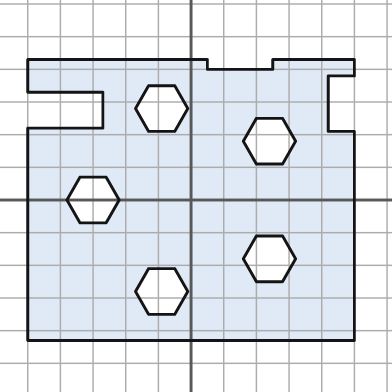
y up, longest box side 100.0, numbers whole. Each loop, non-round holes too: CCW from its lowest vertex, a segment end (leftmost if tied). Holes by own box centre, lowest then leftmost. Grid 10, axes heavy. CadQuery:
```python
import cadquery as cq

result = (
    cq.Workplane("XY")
    .moveTo(-50.0, -43.0)
    .lineTo(50.0, -43.0)
    .lineTo(50.0, 21.0)
    .lineTo(42.0, 21.0)
    .lineTo(42.0, 38.0)
    .lineTo(50.0, 38.0)
    .lineTo(50.0, 43.0)
    .lineTo(25.0, 43.0)
    .lineTo(25.0, 40.0)
    .lineTo(5.0, 40.0)
    .lineTo(5.0, 43.0)
    .lineTo(-50.0, 43.0)
    .lineTo(-50.0, 33.0)
    .lineTo(-27.0, 33.0)
    .lineTo(-27.0, 22.0)
    .lineTo(-50.0, 22.0)
    .close()
    .moveTo(-13.0, -35.0)
    .lineTo(-5.0, -35.0)
    .lineTo(-1.0, -28.0)
    .lineTo(-5.0, -21.0)
    .lineTo(-13.0, -21.0)
    .lineTo(-17.0, -28.0)
    .close()
    .moveTo(20.0, -25.0)
    .lineTo(28.0, -25.0)
    .lineTo(32.0, -18.0)
    .lineTo(28.0, -11.0)
    .lineTo(20.0, -11.0)
    .lineTo(16.0, -18.0)
    .close()
    .moveTo(-34.0, -7.0)
    .lineTo(-26.0, -7.0)
    .lineTo(-22.0, 0.0)
    .lineTo(-26.0, 7.0)
    .lineTo(-34.0, 7.0)
    .lineTo(-38.0, 0.0)
    .close()
    .moveTo(20.0, 11.0)
    .lineTo(28.0, 11.0)
    .lineTo(32.0, 18.0)
    .lineTo(28.0, 25.0)
    .lineTo(20.0, 25.0)
    .lineTo(16.0, 18.0)
    .close()
    .moveTo(-13.0, 21.0)
    .lineTo(-5.0, 21.0)
    .lineTo(-1.0, 28.0)
    .lineTo(-5.0, 35.0)
    .lineTo(-13.0, 35.0)
    .lineTo(-17.0, 28.0)
    .close()
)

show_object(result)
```